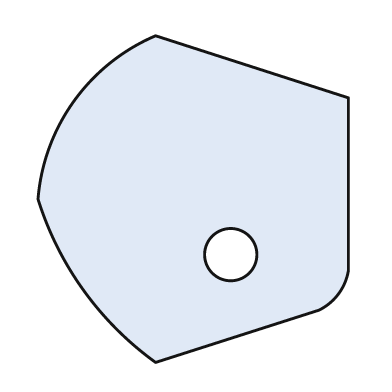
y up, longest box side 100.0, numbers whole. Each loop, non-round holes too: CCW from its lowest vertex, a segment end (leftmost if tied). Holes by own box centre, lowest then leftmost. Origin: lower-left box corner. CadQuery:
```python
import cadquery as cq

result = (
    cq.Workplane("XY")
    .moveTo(36.0, 0.0)
    .lineTo(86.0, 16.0)
    .threePointArc((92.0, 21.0), (95.0, 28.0))
    .lineTo(95.0, 81.0)
    .lineTo(36.0, 100.0)
    .threePointArc((11.0, 80.0), (0.0, 50.0))
    .threePointArc((14.0, 22.0), (36.0, 0.0))
    .close()
    .moveTo(59.0, 33.0)
    .circle(8.0)
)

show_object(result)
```